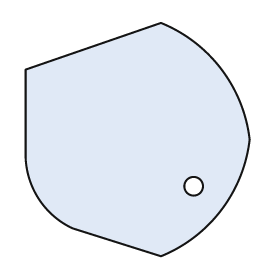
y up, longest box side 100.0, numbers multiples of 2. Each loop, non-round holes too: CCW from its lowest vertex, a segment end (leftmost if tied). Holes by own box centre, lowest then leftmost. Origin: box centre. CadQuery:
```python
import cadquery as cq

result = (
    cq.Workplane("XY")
    .moveTo(10.0, -50.0)
    .threePointArc((36.0, -30.0), (48.0, 0.0))
    .threePointArc((36.0, 30.0), (10.0, 50.0))
    .lineTo(-48.0, 30.0)
    .lineTo(-48.0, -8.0)
    .threePointArc((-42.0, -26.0), (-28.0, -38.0))
    .close()
    .moveTo(24.0, -20.0)
    .circle(4.0)
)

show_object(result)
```